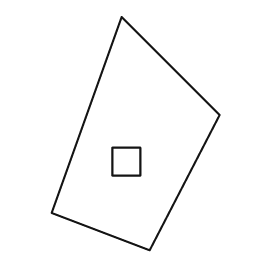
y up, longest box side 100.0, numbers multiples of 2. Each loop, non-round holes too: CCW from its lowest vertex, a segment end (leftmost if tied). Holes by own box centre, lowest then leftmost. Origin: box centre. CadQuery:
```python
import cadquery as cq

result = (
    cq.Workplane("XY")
    .moveTo(6.0, -50.0)
    .lineTo(36.0, 8.0)
    .lineTo(-6.0, 50.0)
    .lineTo(-36.0, -34.0)
    .close()
    .moveTo(-10.0, -18.0)
    .lineTo(2.0, -18.0)
    .lineTo(2.0, -6.0)
    .lineTo(-10.0, -6.0)
    .close()
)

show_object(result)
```